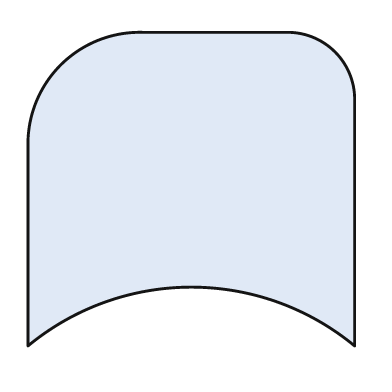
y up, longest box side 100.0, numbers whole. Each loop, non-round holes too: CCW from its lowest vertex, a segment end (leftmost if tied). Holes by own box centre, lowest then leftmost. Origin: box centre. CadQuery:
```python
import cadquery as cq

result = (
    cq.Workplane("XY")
    .moveTo(-50.0, -48.0)
    .threePointArc((0.0, -30.0), (50.0, -48.0))
    .lineTo(50.0, 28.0)
    .threePointArc((44.0, 42.0), (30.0, 48.0))
    .lineTo(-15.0, 48.0)
    .threePointArc((-40.0, 38.0), (-50.0, 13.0))
    .close()
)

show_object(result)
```